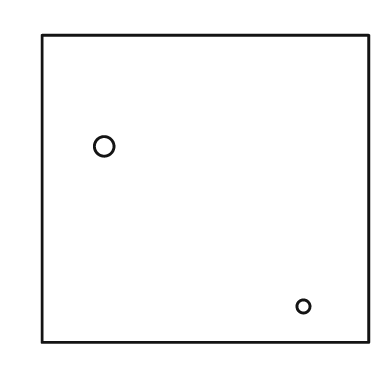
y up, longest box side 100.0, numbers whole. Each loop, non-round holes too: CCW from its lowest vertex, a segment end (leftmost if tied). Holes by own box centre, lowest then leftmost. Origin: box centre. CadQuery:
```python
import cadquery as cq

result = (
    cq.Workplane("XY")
    .moveTo(-50.0, -47.0)
    .lineTo(50.0, -47.0)
    .lineTo(50.0, 47.0)
    .lineTo(-50.0, 47.0)
    .close()
    .moveTo(30.0, -36.0)
    .circle(2.0)
    .moveTo(-31.0, 13.0)
    .circle(3.0)
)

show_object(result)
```